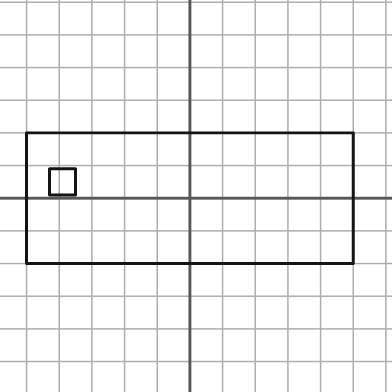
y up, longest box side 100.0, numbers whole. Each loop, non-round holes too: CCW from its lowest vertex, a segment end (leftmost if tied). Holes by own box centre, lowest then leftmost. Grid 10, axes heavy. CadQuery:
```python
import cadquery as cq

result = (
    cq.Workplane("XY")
    .moveTo(-50.0, -20.0)
    .lineTo(50.0, -20.0)
    .lineTo(50.0, 20.0)
    .lineTo(-50.0, 20.0)
    .close()
    .moveTo(-43.0, 1.0)
    .lineTo(-35.0, 1.0)
    .lineTo(-35.0, 9.0)
    .lineTo(-43.0, 9.0)
    .close()
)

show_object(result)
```